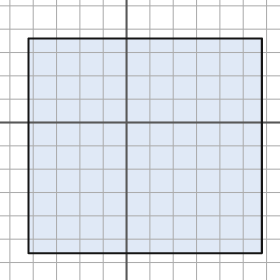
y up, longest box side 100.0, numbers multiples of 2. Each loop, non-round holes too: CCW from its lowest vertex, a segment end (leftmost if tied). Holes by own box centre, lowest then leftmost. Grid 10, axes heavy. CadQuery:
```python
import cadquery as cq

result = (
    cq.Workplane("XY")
    .moveTo(-42.0, -56.0)
    .lineTo(58.0, -56.0)
    .lineTo(58.0, 36.0)
    .lineTo(-42.0, 36.0)
    .close()
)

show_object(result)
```